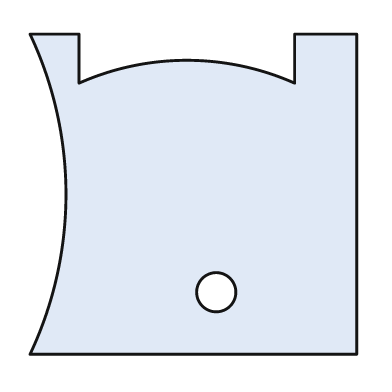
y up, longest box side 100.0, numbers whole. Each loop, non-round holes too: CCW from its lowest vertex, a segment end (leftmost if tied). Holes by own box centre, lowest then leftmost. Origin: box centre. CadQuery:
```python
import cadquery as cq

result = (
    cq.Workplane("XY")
    .moveTo(-50.0, -49.0)
    .lineTo(50.0, -49.0)
    .lineTo(50.0, 49.0)
    .lineTo(31.0, 49.0)
    .lineTo(31.0, 34.0)
    .threePointArc((-2.0, 41.0), (-35.0, 34.0))
    .lineTo(-35.0, 49.0)
    .lineTo(-50.0, 49.0)
    .threePointArc((-39.0, 0.0), (-50.0, -49.0))
    .close()
    .moveTo(7.0, -30.0)
    .circle(6.0)
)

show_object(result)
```